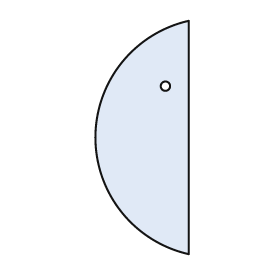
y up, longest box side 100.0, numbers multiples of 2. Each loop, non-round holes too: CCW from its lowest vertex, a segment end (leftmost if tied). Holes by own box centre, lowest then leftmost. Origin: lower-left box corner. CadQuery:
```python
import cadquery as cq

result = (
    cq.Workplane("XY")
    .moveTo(40.0, 0.0)
    .lineTo(40.0, 100.0)
    .threePointArc((0.0, 50.0), (40.0, 0.0))
    .close()
    .moveTo(30.0, 72.0)
    .circle(2.0)
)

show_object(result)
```